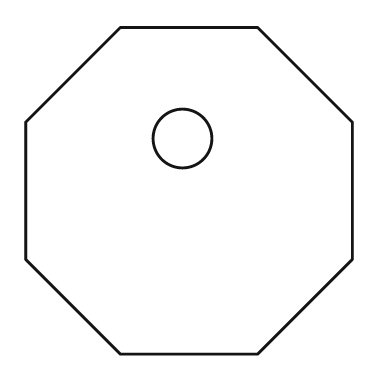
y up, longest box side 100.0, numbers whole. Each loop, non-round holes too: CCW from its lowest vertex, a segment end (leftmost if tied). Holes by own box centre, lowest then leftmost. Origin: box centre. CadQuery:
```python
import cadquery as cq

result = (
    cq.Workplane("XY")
    .moveTo(-21.0, -50.0)
    .lineTo(21.0, -50.0)
    .lineTo(50.0, -21.0)
    .lineTo(50.0, 21.0)
    .lineTo(21.0, 50.0)
    .lineTo(-21.0, 50.0)
    .lineTo(-50.0, 21.0)
    .lineTo(-50.0, -21.0)
    .close()
    .moveTo(-2.0, 16.0)
    .circle(9.0)
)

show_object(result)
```